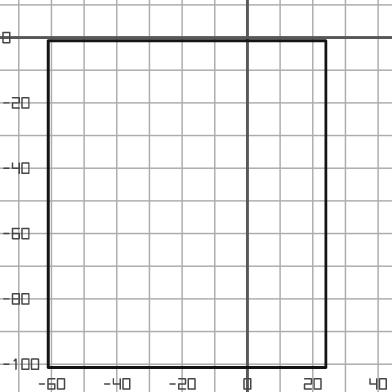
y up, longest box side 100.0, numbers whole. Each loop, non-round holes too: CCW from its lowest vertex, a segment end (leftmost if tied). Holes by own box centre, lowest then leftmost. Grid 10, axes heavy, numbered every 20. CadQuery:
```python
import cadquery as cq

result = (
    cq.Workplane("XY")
    .moveTo(-61.0, -101.0)
    .lineTo(24.0, -101.0)
    .lineTo(24.0, -1.0)
    .lineTo(-61.0, -1.0)
    .close()
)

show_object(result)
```